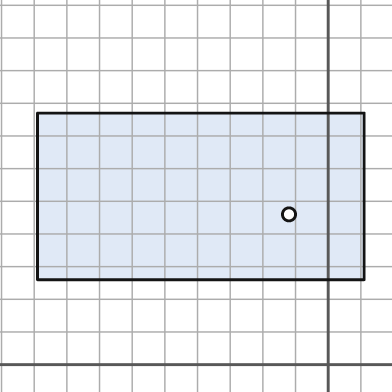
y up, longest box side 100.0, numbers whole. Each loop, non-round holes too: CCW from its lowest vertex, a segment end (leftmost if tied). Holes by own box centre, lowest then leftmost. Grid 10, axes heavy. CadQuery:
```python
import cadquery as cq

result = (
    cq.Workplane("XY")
    .moveTo(-89.0, 26.0)
    .lineTo(11.0, 26.0)
    .lineTo(11.0, 77.0)
    .lineTo(-89.0, 77.0)
    .close()
    .moveTo(-12.0, 46.0)
    .circle(2.0)
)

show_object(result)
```